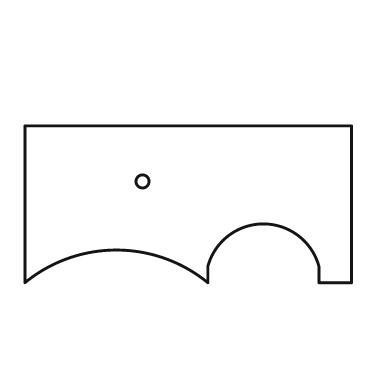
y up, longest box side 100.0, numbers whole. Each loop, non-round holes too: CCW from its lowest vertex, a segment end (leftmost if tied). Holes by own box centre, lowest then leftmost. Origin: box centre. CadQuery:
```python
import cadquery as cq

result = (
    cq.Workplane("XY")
    .moveTo(-50.0, -24.0)
    .threePointArc((-22.0, -14.0), (6.0, -24.0))
    .lineTo(6.0, -19.0)
    .threePointArc((23.0, -6.0), (40.0, -19.0))
    .lineTo(40.0, -24.0)
    .lineTo(50.0, -24.0)
    .lineTo(50.0, 24.0)
    .lineTo(-50.0, 24.0)
    .close()
    .moveTo(-14.0, 7.0)
    .circle(2.0)
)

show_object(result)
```